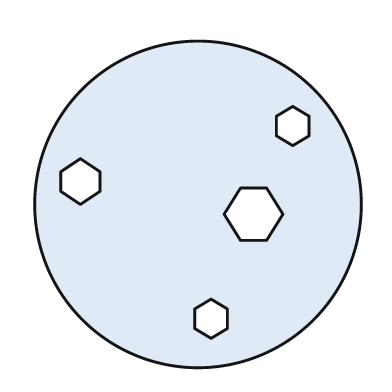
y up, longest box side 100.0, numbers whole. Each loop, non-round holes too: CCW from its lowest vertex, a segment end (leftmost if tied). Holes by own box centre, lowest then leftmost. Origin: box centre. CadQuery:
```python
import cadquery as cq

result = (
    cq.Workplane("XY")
    .moveTo(0.0, 0.0)
    .circle(50.0)
    .moveTo(4.0, -41.0)
    .lineTo(9.0, -38.0)
    .lineTo(9.0, -32.0)
    .lineTo(4.0, -29.0)
    .lineTo(-1.0, -32.0)
    .lineTo(-1.0, -38.0)
    .close()
    .moveTo(13.0, -11.0)
    .lineTo(21.0, -11.0)
    .lineTo(26.0, -3.0)
    .lineTo(21.0, 5.0)
    .lineTo(13.0, 5.0)
    .lineTo(8.0, -3.0)
    .close()
    .moveTo(-36.0, 0.0)
    .lineTo(-30.0, 4.0)
    .lineTo(-30.0, 10.0)
    .lineTo(-36.0, 14.0)
    .lineTo(-42.0, 10.0)
    .lineTo(-42.0, 4.0)
    .close()
    .moveTo(29.0, 18.0)
    .lineTo(34.0, 21.0)
    .lineTo(34.0, 27.0)
    .lineTo(29.0, 30.0)
    .lineTo(24.0, 27.0)
    .lineTo(24.0, 21.0)
    .close()
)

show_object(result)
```